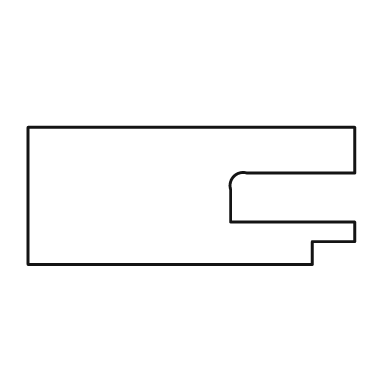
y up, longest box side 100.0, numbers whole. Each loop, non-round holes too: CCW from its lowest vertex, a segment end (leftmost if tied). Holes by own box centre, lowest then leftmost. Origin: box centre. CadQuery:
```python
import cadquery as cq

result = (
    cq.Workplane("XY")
    .moveTo(-50.0, -21.0)
    .lineTo(37.0, -21.0)
    .lineTo(37.0, -14.0)
    .lineTo(50.0, -14.0)
    .lineTo(50.0, -8.0)
    .lineTo(12.0, -8.0)
    .lineTo(12.0, 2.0)
    .threePointArc((13.0, 6.0), (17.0, 7.0))
    .lineTo(50.0, 7.0)
    .lineTo(50.0, 21.0)
    .lineTo(-50.0, 21.0)
    .close()
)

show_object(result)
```